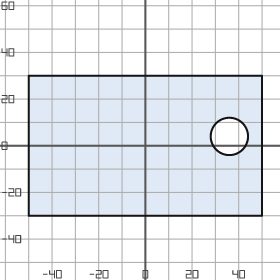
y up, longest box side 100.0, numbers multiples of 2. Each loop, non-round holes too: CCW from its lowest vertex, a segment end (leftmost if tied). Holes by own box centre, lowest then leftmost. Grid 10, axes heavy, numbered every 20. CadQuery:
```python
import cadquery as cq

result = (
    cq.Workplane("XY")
    .moveTo(-50.0, -30.0)
    .lineTo(50.0, -30.0)
    .lineTo(50.0, 30.0)
    .lineTo(-50.0, 30.0)
    .close()
    .moveTo(36.0, 4.0)
    .circle(8.0)
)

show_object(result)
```